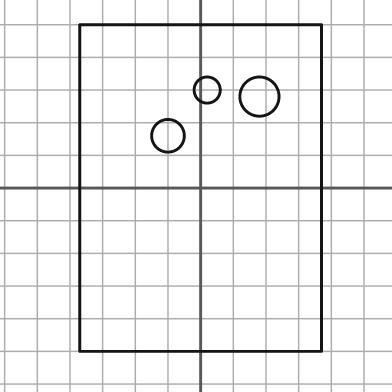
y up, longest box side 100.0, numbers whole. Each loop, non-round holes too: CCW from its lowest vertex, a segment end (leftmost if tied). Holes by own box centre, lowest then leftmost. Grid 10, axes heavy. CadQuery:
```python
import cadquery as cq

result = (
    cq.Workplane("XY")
    .moveTo(-37.0, -50.0)
    .lineTo(37.0, -50.0)
    .lineTo(37.0, 50.0)
    .lineTo(-37.0, 50.0)
    .close()
    .moveTo(-10.0, 16.0)
    .circle(5.0)
    .moveTo(18.0, 28.0)
    .circle(6.0)
    .moveTo(2.0, 30.0)
    .circle(4.0)
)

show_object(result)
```